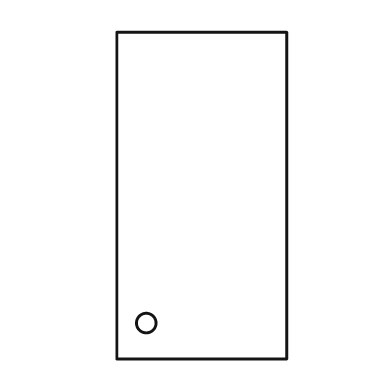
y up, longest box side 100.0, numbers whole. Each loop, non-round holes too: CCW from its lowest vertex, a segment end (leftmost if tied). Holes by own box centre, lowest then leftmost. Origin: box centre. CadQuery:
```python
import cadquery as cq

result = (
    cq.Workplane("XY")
    .moveTo(-26.0, -50.0)
    .lineTo(26.0, -50.0)
    .lineTo(26.0, 50.0)
    .lineTo(-26.0, 50.0)
    .close()
    .moveTo(-17.0, -39.0)
    .circle(3.0)
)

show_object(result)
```